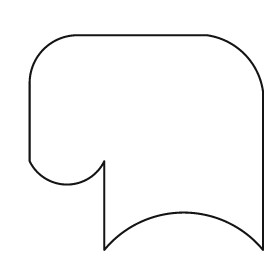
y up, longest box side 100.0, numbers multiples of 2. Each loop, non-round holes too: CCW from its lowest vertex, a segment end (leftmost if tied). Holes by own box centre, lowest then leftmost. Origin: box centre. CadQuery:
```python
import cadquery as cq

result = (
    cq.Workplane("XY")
    .moveTo(-18.0, -46.0)
    .threePointArc((16.0, -30.0), (50.0, -46.0))
    .lineTo(50.0, 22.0)
    .threePointArc((42.0, 38.0), (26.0, 46.0))
    .lineTo(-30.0, 46.0)
    .threePointArc((-44.0, 40.0), (-50.0, 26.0))
    .lineTo(-50.0, -8.0)
    .threePointArc((-34.0, -18.0), (-18.0, -8.0))
    .close()
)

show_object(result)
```